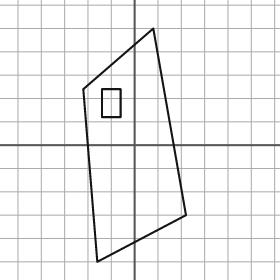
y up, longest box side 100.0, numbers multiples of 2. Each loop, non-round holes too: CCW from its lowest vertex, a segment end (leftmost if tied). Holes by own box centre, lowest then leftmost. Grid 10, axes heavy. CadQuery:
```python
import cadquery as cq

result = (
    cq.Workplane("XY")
    .moveTo(-16.0, -50.0)
    .lineTo(22.0, -30.0)
    .lineTo(8.0, 50.0)
    .lineTo(-22.0, 24.0)
    .close()
    .moveTo(-14.0, 12.0)
    .lineTo(-6.0, 12.0)
    .lineTo(-6.0, 24.0)
    .lineTo(-14.0, 24.0)
    .close()
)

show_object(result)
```